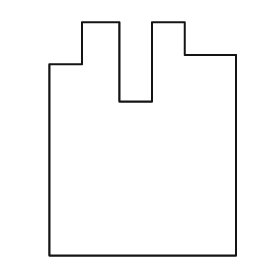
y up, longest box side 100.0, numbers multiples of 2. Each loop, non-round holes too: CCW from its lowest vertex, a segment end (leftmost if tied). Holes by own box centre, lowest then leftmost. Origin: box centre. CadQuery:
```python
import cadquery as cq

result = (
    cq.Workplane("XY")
    .moveTo(-40.0, -50.0)
    .lineTo(40.0, -50.0)
    .lineTo(40.0, 36.0)
    .lineTo(18.0, 36.0)
    .lineTo(18.0, 50.0)
    .lineTo(4.0, 50.0)
    .lineTo(4.0, 16.0)
    .lineTo(-10.0, 16.0)
    .lineTo(-10.0, 50.0)
    .lineTo(-26.0, 50.0)
    .lineTo(-26.0, 32.0)
    .lineTo(-40.0, 32.0)
    .close()
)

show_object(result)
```